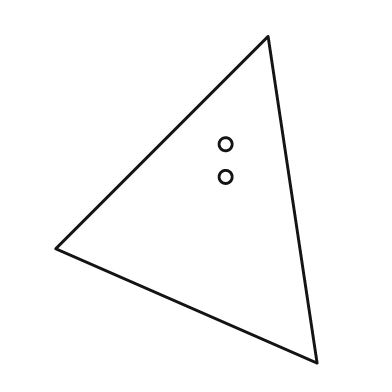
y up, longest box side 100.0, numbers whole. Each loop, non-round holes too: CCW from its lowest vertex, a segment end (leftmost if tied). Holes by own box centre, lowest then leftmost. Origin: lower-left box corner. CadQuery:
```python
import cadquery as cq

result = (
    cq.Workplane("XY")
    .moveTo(80.0, 0.0)
    .lineTo(65.0, 100.0)
    .lineTo(0.0, 35.0)
    .close()
    .moveTo(52.0, 57.0)
    .circle(2.0)
    .moveTo(52.0, 67.0)
    .circle(2.0)
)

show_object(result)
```